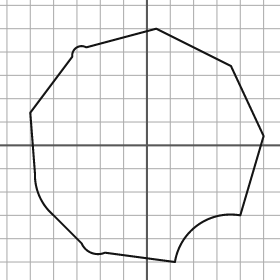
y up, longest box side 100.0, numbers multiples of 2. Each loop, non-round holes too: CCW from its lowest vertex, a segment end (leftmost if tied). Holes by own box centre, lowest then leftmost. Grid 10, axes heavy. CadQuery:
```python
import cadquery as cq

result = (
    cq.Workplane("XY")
    .moveTo(12.0, -50.0)
    .threePointArc((22.0, -34.0), (40.0, -30.0))
    .lineTo(50.0, 4.0)
    .lineTo(36.0, 34.0)
    .lineTo(4.0, 50.0)
    .lineTo(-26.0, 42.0)
    .threePointArc((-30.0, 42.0), (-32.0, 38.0))
    .lineTo(-50.0, 14.0)
    .lineTo(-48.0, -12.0)
    .threePointArc((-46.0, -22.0), (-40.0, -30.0))
    .lineTo(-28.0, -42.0)
    .threePointArc((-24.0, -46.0), (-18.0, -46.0))
    .close()
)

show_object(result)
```